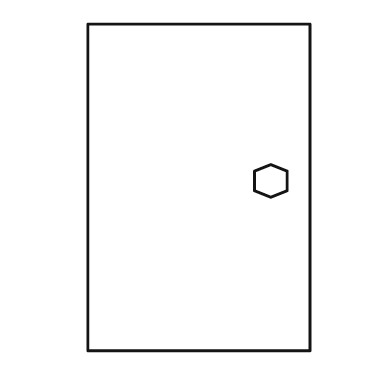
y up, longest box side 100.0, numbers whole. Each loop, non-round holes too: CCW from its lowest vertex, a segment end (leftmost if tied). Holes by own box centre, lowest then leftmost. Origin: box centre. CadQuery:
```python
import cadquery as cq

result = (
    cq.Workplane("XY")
    .moveTo(-34.0, -50.0)
    .lineTo(34.0, -50.0)
    .lineTo(34.0, 50.0)
    .lineTo(-34.0, 50.0)
    .close()
    .moveTo(22.0, -3.0)
    .lineTo(27.0, -1.0)
    .lineTo(27.0, 5.0)
    .lineTo(22.0, 7.0)
    .lineTo(17.0, 5.0)
    .lineTo(17.0, -1.0)
    .close()
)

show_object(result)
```